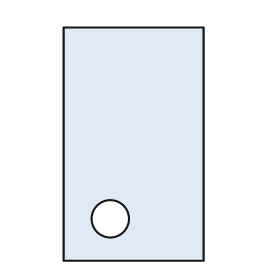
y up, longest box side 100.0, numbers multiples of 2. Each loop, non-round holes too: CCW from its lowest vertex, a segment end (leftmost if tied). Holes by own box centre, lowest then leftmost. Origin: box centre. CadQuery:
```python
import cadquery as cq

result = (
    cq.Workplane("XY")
    .moveTo(-30.0, -50.0)
    .lineTo(30.0, -50.0)
    .lineTo(30.0, 50.0)
    .lineTo(-30.0, 50.0)
    .close()
    .moveTo(-10.0, -32.0)
    .circle(8.0)
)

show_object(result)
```